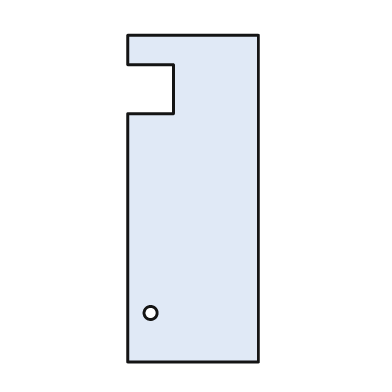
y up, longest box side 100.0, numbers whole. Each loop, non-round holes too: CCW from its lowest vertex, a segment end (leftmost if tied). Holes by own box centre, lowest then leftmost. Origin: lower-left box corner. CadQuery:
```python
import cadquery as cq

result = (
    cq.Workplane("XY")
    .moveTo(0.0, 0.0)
    .lineTo(40.0, 0.0)
    .lineTo(40.0, 100.0)
    .lineTo(0.0, 100.0)
    .lineTo(0.0, 91.0)
    .lineTo(14.0, 91.0)
    .lineTo(14.0, 76.0)
    .lineTo(0.0, 76.0)
    .close()
    .moveTo(7.0, 15.0)
    .circle(2.0)
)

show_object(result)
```